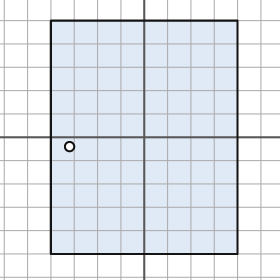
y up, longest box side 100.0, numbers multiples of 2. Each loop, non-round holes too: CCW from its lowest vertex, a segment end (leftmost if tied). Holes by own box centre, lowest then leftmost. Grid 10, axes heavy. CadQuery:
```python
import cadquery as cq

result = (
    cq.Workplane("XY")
    .moveTo(-40.0, -50.0)
    .lineTo(40.0, -50.0)
    .lineTo(40.0, 50.0)
    .lineTo(-40.0, 50.0)
    .close()
    .moveTo(-32.0, -4.0)
    .circle(2.0)
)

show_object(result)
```